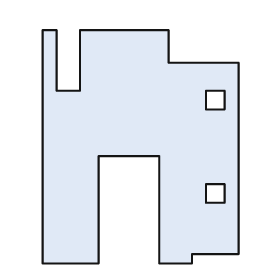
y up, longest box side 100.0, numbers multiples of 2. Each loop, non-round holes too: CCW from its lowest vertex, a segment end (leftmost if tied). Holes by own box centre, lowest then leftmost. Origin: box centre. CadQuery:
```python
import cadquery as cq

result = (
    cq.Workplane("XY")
    .moveTo(-42.0, -50.0)
    .lineTo(-18.0, -50.0)
    .lineTo(-18.0, -4.0)
    .lineTo(8.0, -4.0)
    .lineTo(8.0, -50.0)
    .lineTo(22.0, -50.0)
    .lineTo(22.0, -46.0)
    .lineTo(42.0, -46.0)
    .lineTo(42.0, 36.0)
    .lineTo(12.0, 36.0)
    .lineTo(12.0, 50.0)
    .lineTo(-26.0, 50.0)
    .lineTo(-26.0, 24.0)
    .lineTo(-36.0, 24.0)
    .lineTo(-36.0, 50.0)
    .lineTo(-42.0, 50.0)
    .close()
    .moveTo(28.0, -24.0)
    .lineTo(36.0, -24.0)
    .lineTo(36.0, -16.0)
    .lineTo(28.0, -16.0)
    .close()
    .moveTo(28.0, 16.0)
    .lineTo(36.0, 16.0)
    .lineTo(36.0, 24.0)
    .lineTo(28.0, 24.0)
    .close()
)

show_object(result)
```